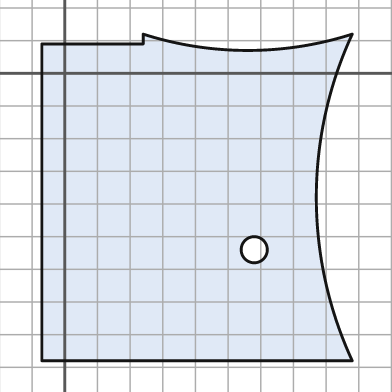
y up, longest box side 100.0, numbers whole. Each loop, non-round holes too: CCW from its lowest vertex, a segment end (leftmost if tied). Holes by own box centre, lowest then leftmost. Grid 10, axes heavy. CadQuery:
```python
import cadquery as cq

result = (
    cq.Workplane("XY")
    .moveTo(-7.0, -88.0)
    .lineTo(88.0, -88.0)
    .threePointArc((77.0, -38.0), (88.0, 12.0))
    .threePointArc((56.0, 7.0), (24.0, 12.0))
    .lineTo(24.0, 9.0)
    .lineTo(-7.0, 9.0)
    .close()
    .moveTo(58.0, -54.0)
    .circle(4.0)
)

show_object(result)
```